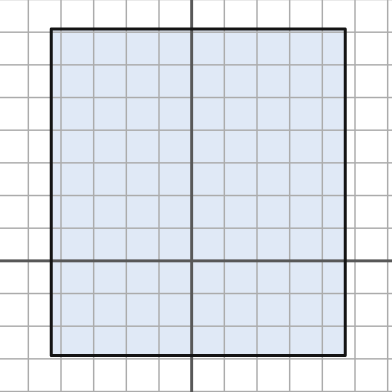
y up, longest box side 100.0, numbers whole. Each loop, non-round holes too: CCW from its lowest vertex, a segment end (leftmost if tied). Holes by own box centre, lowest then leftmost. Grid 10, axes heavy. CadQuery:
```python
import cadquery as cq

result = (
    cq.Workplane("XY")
    .moveTo(-43.0, -29.0)
    .lineTo(47.0, -29.0)
    .lineTo(47.0, 71.0)
    .lineTo(-43.0, 71.0)
    .close()
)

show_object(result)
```